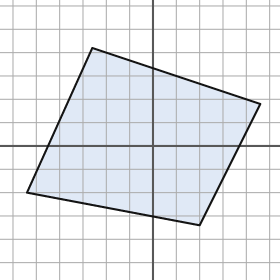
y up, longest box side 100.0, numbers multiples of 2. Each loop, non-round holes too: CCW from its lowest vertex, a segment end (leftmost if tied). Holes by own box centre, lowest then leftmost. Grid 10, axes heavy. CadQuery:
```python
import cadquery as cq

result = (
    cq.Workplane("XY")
    .moveTo(20.0, -34.0)
    .lineTo(46.0, 18.0)
    .lineTo(-26.0, 42.0)
    .lineTo(-54.0, -20.0)
    .close()
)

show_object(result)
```